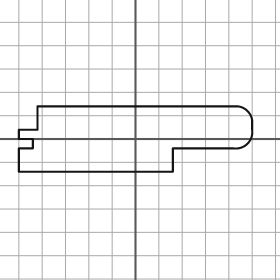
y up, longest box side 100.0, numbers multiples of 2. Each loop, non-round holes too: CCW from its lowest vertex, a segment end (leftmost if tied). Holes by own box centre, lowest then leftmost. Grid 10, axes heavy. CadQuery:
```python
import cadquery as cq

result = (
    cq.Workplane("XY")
    .moveTo(-50.0, -14.0)
    .lineTo(16.0, -14.0)
    .lineTo(16.0, -4.0)
    .lineTo(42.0, -4.0)
    .threePointArc((48.0, -2.0), (50.0, 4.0))
    .lineTo(50.0, 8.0)
    .threePointArc((48.0, 12.0), (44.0, 14.0))
    .lineTo(-42.0, 14.0)
    .lineTo(-42.0, 4.0)
    .lineTo(-50.0, 4.0)
    .lineTo(-50.0, 0.0)
    .lineTo(-44.0, 0.0)
    .lineTo(-44.0, -4.0)
    .lineTo(-50.0, -4.0)
    .close()
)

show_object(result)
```